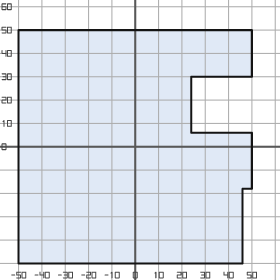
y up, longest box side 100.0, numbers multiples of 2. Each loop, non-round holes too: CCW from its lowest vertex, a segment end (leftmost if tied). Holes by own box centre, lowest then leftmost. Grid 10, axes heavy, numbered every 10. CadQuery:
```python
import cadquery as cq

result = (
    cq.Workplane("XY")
    .moveTo(-50.0, -50.0)
    .lineTo(46.0, -50.0)
    .lineTo(46.0, -18.0)
    .lineTo(50.0, -18.0)
    .lineTo(50.0, 6.0)
    .lineTo(24.0, 6.0)
    .lineTo(24.0, 30.0)
    .lineTo(50.0, 30.0)
    .lineTo(50.0, 50.0)
    .lineTo(-50.0, 50.0)
    .close()
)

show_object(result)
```